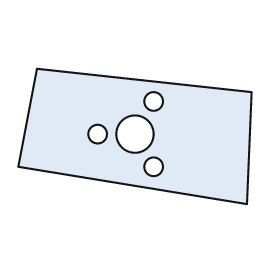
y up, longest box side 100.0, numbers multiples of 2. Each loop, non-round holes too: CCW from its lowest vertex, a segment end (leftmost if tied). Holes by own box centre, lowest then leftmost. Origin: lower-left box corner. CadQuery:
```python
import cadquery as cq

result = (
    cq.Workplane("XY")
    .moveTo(98.0, 0.0)
    .lineTo(100.0, 48.0)
    .lineTo(8.0, 58.0)
    .lineTo(0.0, 16.0)
    .close()
    .moveTo(58.0, 16.0)
    .circle(4.0)
    .moveTo(34.0, 30.0)
    .circle(4.0)
    .moveTo(50.0, 30.0)
    .circle(8.0)
    .moveTo(58.0, 44.0)
    .circle(4.0)
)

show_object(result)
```